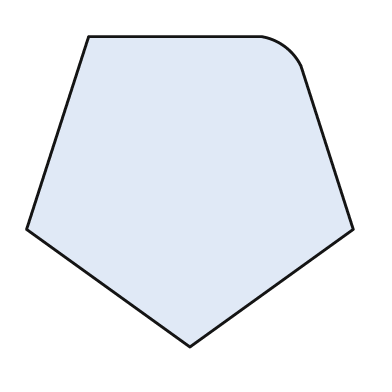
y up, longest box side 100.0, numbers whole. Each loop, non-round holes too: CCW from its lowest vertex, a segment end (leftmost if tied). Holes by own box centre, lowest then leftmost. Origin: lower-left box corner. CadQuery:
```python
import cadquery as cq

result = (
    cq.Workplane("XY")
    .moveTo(50.0, 0.0)
    .lineTo(100.0, 36.0)
    .lineTo(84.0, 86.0)
    .threePointArc((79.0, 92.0), (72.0, 95.0))
    .lineTo(19.0, 95.0)
    .lineTo(0.0, 36.0)
    .close()
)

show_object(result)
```